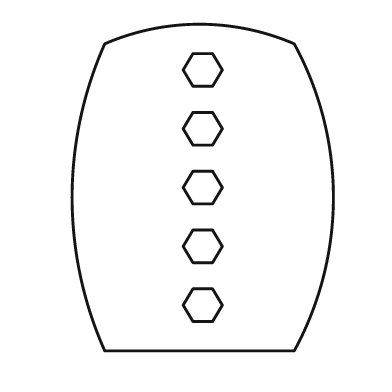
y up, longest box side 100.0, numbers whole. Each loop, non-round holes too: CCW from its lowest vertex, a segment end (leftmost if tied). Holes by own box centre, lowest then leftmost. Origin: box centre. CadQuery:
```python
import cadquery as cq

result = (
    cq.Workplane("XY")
    .moveTo(-30.0, -50.0)
    .lineTo(28.0, -50.0)
    .threePointArc((40.0, -3.0), (28.0, 44.0))
    .threePointArc((-1.0, 50.0), (-30.0, 44.0))
    .threePointArc((-40.0, -3.0), (-30.0, -50.0))
    .close()
    .moveTo(-3.0, -41.0)
    .lineTo(3.0, -41.0)
    .lineTo(6.0, -36.0)
    .lineTo(3.0, -31.0)
    .lineTo(-3.0, -31.0)
    .lineTo(-6.0, -36.0)
    .close()
    .moveTo(-3.0, -23.0)
    .lineTo(3.0, -23.0)
    .lineTo(6.0, -18.0)
    .lineTo(3.0, -13.0)
    .lineTo(-3.0, -13.0)
    .lineTo(-6.0, -18.0)
    .close()
    .moveTo(-3.0, -5.0)
    .lineTo(3.0, -5.0)
    .lineTo(6.0, 0.0)
    .lineTo(3.0, 5.0)
    .lineTo(-3.0, 5.0)
    .lineTo(-6.0, 0.0)
    .close()
    .moveTo(-3.0, 13.0)
    .lineTo(3.0, 13.0)
    .lineTo(6.0, 18.0)
    .lineTo(3.0, 23.0)
    .lineTo(-3.0, 23.0)
    .lineTo(-6.0, 18.0)
    .close()
    .moveTo(-3.0, 31.0)
    .lineTo(3.0, 31.0)
    .lineTo(6.0, 36.0)
    .lineTo(3.0, 41.0)
    .lineTo(-3.0, 41.0)
    .lineTo(-6.0, 36.0)
    .close()
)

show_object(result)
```